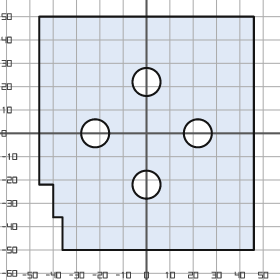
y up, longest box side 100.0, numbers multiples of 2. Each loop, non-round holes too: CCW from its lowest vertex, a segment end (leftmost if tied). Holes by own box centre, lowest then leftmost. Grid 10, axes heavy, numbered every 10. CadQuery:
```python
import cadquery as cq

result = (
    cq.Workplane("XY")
    .moveTo(-36.0, -50.0)
    .lineTo(46.0, -50.0)
    .lineTo(46.0, 50.0)
    .lineTo(-46.0, 50.0)
    .lineTo(-46.0, -22.0)
    .lineTo(-40.0, -22.0)
    .lineTo(-40.0, -36.0)
    .lineTo(-36.0, -36.0)
    .close()
    .moveTo(0.0, -22.0)
    .circle(6.0)
    .moveTo(-22.0, 0.0)
    .circle(6.0)
    .moveTo(22.0, 0.0)
    .circle(6.0)
    .moveTo(0.0, 22.0)
    .circle(6.0)
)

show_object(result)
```